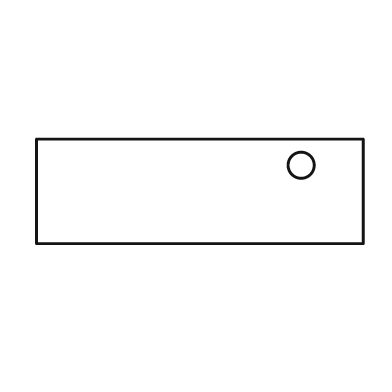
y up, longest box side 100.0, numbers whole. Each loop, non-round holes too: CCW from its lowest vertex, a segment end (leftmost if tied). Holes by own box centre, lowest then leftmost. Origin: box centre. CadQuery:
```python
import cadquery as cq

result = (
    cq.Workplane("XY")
    .moveTo(-50.0, -16.0)
    .lineTo(50.0, -16.0)
    .lineTo(50.0, 16.0)
    .lineTo(-50.0, 16.0)
    .close()
    .moveTo(31.0, 8.0)
    .circle(4.0)
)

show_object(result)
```